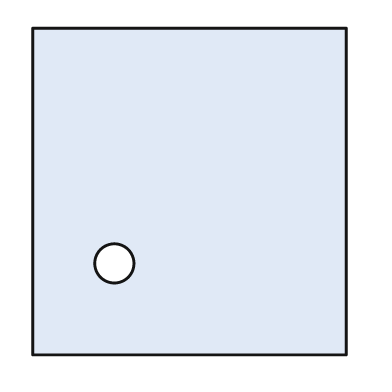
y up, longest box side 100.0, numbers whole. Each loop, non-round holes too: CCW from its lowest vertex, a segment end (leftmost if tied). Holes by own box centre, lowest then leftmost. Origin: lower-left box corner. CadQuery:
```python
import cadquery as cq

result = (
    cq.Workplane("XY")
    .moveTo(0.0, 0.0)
    .lineTo(96.0, 0.0)
    .lineTo(96.0, 100.0)
    .lineTo(0.0, 100.0)
    .close()
    .moveTo(25.0, 28.0)
    .circle(6.0)
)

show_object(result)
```